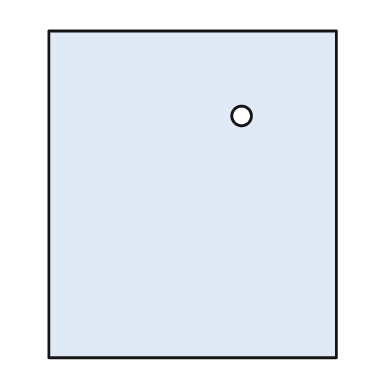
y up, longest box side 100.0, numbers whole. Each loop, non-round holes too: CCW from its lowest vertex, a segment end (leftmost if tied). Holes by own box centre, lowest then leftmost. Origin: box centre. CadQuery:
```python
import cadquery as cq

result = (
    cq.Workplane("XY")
    .moveTo(-44.0, -50.0)
    .lineTo(44.0, -50.0)
    .lineTo(44.0, 50.0)
    .lineTo(-44.0, 50.0)
    .close()
    .moveTo(15.0, 24.0)
    .circle(3.0)
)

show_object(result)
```